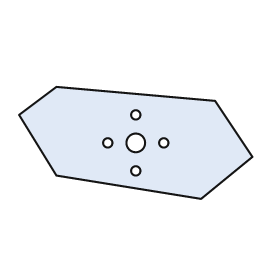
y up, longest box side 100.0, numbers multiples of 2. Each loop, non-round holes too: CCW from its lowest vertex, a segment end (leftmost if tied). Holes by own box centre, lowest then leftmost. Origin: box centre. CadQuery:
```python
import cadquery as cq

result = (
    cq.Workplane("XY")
    .moveTo(28.0, -24.0)
    .lineTo(50.0, -6.0)
    .lineTo(34.0, 18.0)
    .lineTo(-34.0, 24.0)
    .lineTo(-50.0, 12.0)
    .lineTo(-34.0, -14.0)
    .close()
    .moveTo(0.0, -12.0)
    .circle(2.0)
    .moveTo(-12.0, 0.0)
    .circle(2.0)
    .moveTo(0.0, 0.0)
    .circle(4.0)
    .moveTo(12.0, 0.0)
    .circle(2.0)
    .moveTo(0.0, 12.0)
    .circle(2.0)
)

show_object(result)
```